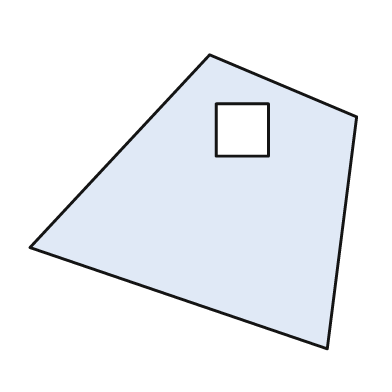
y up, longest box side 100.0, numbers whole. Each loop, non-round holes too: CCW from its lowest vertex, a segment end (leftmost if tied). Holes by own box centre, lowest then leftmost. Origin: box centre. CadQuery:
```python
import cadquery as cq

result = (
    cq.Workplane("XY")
    .moveTo(41.0, -45.0)
    .lineTo(50.0, 26.0)
    .lineTo(5.0, 45.0)
    .lineTo(-50.0, -14.0)
    .close()
    .moveTo(7.0, 14.0)
    .lineTo(23.0, 14.0)
    .lineTo(23.0, 30.0)
    .lineTo(7.0, 30.0)
    .close()
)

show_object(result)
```